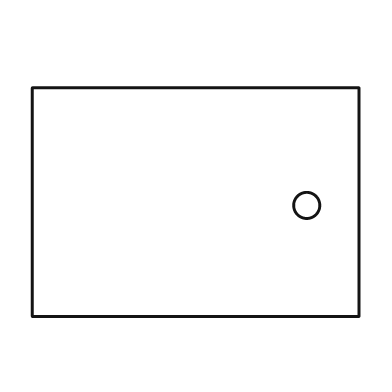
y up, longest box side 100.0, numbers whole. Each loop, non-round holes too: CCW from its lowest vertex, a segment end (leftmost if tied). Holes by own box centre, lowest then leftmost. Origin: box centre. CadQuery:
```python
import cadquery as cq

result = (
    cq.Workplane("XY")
    .moveTo(-50.0, -35.0)
    .lineTo(50.0, -35.0)
    .lineTo(50.0, 35.0)
    .lineTo(-50.0, 35.0)
    .close()
    .moveTo(34.0, -1.0)
    .circle(4.0)
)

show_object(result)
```